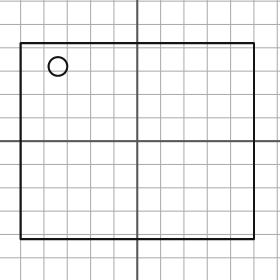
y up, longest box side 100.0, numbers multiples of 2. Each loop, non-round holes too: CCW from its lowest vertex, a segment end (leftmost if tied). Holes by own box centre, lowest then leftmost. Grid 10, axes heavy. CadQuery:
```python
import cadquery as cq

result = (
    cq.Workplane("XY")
    .moveTo(-50.0, -42.0)
    .lineTo(50.0, -42.0)
    .lineTo(50.0, 42.0)
    .lineTo(-50.0, 42.0)
    .close()
    .moveTo(-34.0, 32.0)
    .circle(4.0)
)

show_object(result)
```